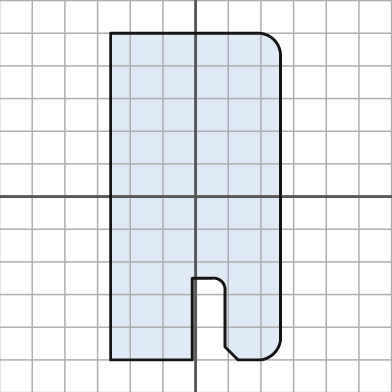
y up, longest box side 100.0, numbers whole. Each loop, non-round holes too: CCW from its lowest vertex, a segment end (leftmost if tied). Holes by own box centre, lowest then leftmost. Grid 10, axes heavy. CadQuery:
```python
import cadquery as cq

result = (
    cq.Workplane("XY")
    .moveTo(-26.0, -50.0)
    .lineTo(-1.0, -50.0)
    .lineTo(-1.0, -25.0)
    .lineTo(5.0, -25.0)
    .threePointArc((8.0, -26.0), (9.0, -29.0))
    .lineTo(9.0, -46.0)
    .lineTo(13.0, -50.0)
    .lineTo(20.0, -50.0)
    .threePointArc((24.0, -48.0), (26.0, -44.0))
    .lineTo(26.0, 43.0)
    .threePointArc((24.0, 48.0), (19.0, 50.0))
    .lineTo(-26.0, 50.0)
    .close()
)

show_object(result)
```